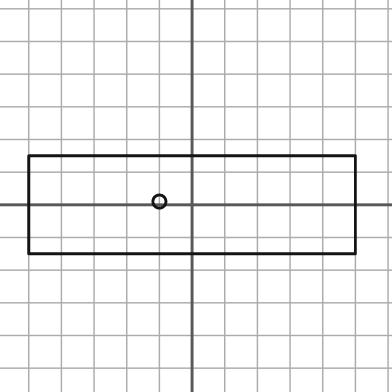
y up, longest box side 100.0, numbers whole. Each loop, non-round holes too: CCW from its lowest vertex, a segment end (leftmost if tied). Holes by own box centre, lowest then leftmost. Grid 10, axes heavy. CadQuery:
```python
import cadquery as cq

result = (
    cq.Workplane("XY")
    .moveTo(-50.0, -15.0)
    .lineTo(50.0, -15.0)
    .lineTo(50.0, 15.0)
    .lineTo(-50.0, 15.0)
    .close()
    .moveTo(-10.0, 1.0)
    .circle(2.0)
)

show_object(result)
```